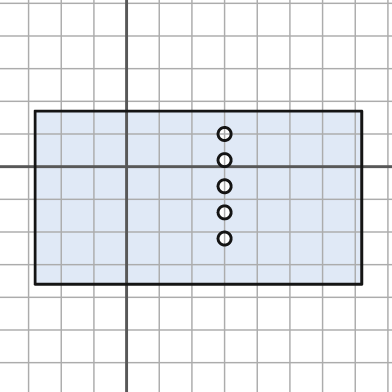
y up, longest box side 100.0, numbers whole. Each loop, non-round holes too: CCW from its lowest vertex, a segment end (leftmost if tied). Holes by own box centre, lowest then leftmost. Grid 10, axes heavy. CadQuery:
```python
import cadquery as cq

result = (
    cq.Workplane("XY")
    .moveTo(-28.0, -36.0)
    .lineTo(72.0, -36.0)
    .lineTo(72.0, 17.0)
    .lineTo(-28.0, 17.0)
    .close()
    .moveTo(30.0, -22.0)
    .circle(2.0)
    .moveTo(30.0, -14.0)
    .circle(2.0)
    .moveTo(30.0, -6.0)
    .circle(2.0)
    .moveTo(30.0, 2.0)
    .circle(2.0)
    .moveTo(30.0, 10.0)
    .circle(2.0)
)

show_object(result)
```